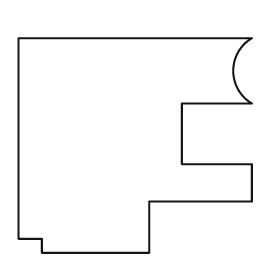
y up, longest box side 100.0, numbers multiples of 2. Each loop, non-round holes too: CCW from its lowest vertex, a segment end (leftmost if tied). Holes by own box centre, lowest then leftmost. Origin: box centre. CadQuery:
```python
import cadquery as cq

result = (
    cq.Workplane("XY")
    .moveTo(-40.0, -46.0)
    .lineTo(6.0, -46.0)
    .lineTo(6.0, -24.0)
    .lineTo(50.0, -24.0)
    .lineTo(50.0, -8.0)
    .lineTo(20.0, -8.0)
    .lineTo(20.0, 18.0)
    .lineTo(50.0, 18.0)
    .threePointArc((42.0, 32.0), (50.0, 46.0))
    .lineTo(-50.0, 46.0)
    .lineTo(-50.0, -40.0)
    .lineTo(-40.0, -40.0)
    .close()
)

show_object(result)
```